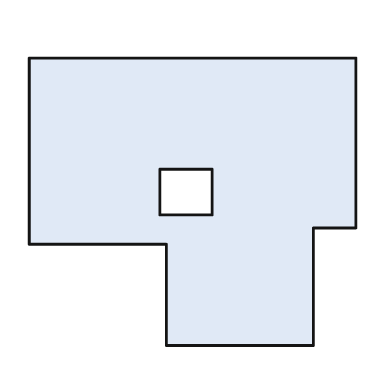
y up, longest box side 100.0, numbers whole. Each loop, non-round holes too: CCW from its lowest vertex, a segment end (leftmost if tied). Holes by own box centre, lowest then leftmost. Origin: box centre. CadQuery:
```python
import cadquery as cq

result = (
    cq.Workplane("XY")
    .moveTo(-8.0, -44.0)
    .lineTo(37.0, -44.0)
    .lineTo(37.0, -8.0)
    .lineTo(50.0, -8.0)
    .lineTo(50.0, 44.0)
    .lineTo(-50.0, 44.0)
    .lineTo(-50.0, -13.0)
    .lineTo(-8.0, -13.0)
    .close()
    .moveTo(-10.0, -4.0)
    .lineTo(6.0, -4.0)
    .lineTo(6.0, 10.0)
    .lineTo(-10.0, 10.0)
    .close()
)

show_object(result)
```